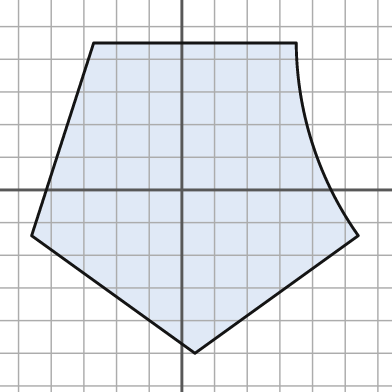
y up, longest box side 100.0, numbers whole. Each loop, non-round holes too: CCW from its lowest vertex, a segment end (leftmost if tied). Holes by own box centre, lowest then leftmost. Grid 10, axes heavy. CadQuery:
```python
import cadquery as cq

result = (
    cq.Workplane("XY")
    .moveTo(4.0, -50.0)
    .lineTo(54.0, -14.0)
    .threePointArc((40.0, 14.0), (35.0, 45.0))
    .lineTo(-27.0, 45.0)
    .lineTo(-46.0, -14.0)
    .close()
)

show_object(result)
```